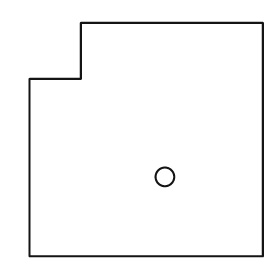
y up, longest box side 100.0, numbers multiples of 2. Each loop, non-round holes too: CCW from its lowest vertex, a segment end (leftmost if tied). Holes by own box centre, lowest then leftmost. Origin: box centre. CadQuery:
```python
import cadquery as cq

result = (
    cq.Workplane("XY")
    .moveTo(-50.0, -50.0)
    .lineTo(50.0, -50.0)
    .lineTo(50.0, 50.0)
    .lineTo(-28.0, 50.0)
    .lineTo(-28.0, 26.0)
    .lineTo(-50.0, 26.0)
    .close()
    .moveTo(8.0, -16.0)
    .circle(4.0)
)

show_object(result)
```